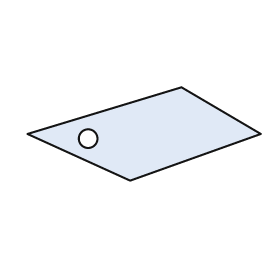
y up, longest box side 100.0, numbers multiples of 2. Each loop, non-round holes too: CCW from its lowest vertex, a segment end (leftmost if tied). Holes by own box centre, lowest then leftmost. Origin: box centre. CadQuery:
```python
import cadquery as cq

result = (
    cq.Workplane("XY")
    .moveTo(-6.0, -20.0)
    .lineTo(50.0, 0.0)
    .lineTo(16.0, 20.0)
    .lineTo(-50.0, 0.0)
    .close()
    .moveTo(-24.0, -2.0)
    .circle(4.0)
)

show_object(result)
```